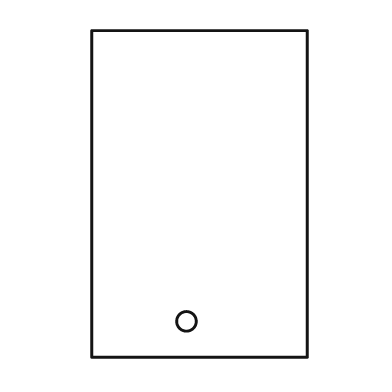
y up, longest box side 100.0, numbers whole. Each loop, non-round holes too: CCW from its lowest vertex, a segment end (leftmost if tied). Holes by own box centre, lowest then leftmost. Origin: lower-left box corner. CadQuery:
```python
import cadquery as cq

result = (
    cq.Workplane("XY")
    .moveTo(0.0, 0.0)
    .lineTo(66.0, 0.0)
    .lineTo(66.0, 100.0)
    .lineTo(0.0, 100.0)
    .close()
    .moveTo(29.0, 11.0)
    .circle(3.0)
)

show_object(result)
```